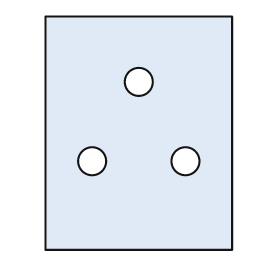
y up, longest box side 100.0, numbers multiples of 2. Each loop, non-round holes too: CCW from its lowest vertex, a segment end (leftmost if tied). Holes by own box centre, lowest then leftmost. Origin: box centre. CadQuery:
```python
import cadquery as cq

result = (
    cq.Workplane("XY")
    .moveTo(-40.0, -50.0)
    .lineTo(40.0, -50.0)
    .lineTo(40.0, 50.0)
    .lineTo(-40.0, 50.0)
    .close()
    .moveTo(-20.0, -12.0)
    .circle(6.0)
    .moveTo(20.0, -12.0)
    .circle(6.0)
    .moveTo(0.0, 22.0)
    .circle(6.0)
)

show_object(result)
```